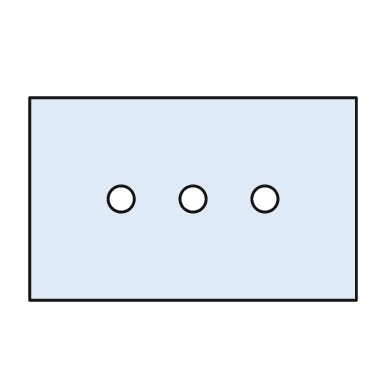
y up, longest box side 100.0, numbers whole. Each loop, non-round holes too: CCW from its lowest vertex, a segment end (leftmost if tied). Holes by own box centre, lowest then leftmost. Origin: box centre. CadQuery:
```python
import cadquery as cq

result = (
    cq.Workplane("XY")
    .moveTo(-50.0, -31.0)
    .lineTo(50.0, -31.0)
    .lineTo(50.0, 31.0)
    .lineTo(-50.0, 31.0)
    .close()
    .moveTo(-22.0, 0.0)
    .circle(4.0)
    .moveTo(0.0, 0.0)
    .circle(4.0)
    .moveTo(22.0, 0.0)
    .circle(4.0)
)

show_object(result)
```